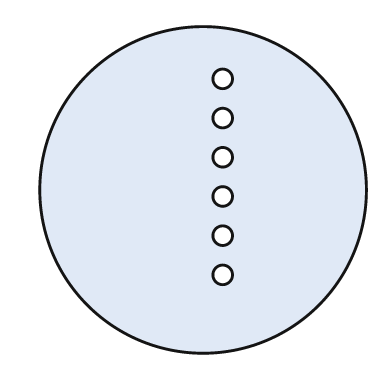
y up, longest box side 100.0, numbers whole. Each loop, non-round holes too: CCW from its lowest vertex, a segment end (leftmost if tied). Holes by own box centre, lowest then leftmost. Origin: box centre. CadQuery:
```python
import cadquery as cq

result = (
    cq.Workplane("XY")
    .moveTo(0.0, 0.0)
    .circle(50.0)
    .moveTo(6.0, -26.0)
    .circle(3.0)
    .moveTo(6.0, -14.0)
    .circle(3.0)
    .moveTo(6.0, -2.0)
    .circle(3.0)
    .moveTo(6.0, 10.0)
    .circle(3.0)
    .moveTo(6.0, 22.0)
    .circle(3.0)
    .moveTo(6.0, 34.0)
    .circle(3.0)
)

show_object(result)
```